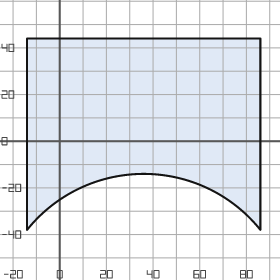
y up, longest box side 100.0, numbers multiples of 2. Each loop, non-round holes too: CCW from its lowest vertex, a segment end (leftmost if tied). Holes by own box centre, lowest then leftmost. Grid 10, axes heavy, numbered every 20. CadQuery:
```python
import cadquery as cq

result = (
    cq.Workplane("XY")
    .moveTo(-14.0, -38.0)
    .threePointArc((36.0, -14.0), (86.0, -38.0))
    .lineTo(86.0, 44.0)
    .lineTo(-14.0, 44.0)
    .close()
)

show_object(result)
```